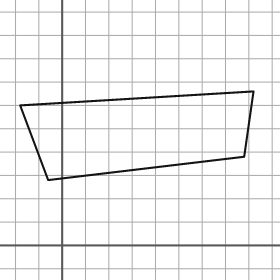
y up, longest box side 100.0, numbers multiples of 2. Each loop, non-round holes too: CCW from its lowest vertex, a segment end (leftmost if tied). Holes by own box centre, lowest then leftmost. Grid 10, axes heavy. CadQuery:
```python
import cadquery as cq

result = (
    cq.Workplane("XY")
    .moveTo(-6.0, 28.0)
    .lineTo(78.0, 38.0)
    .lineTo(82.0, 66.0)
    .lineTo(-18.0, 60.0)
    .close()
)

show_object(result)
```